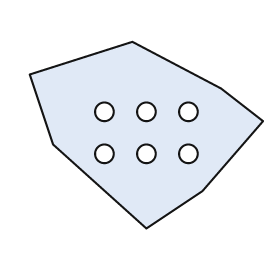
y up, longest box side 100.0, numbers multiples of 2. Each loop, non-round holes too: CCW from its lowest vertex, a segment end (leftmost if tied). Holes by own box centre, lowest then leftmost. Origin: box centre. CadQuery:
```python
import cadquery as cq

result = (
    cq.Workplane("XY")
    .moveTo(0.0, -40.0)
    .lineTo(24.0, -24.0)
    .lineTo(50.0, 6.0)
    .lineTo(32.0, 20.0)
    .lineTo(-6.0, 40.0)
    .lineTo(-50.0, 26.0)
    .lineTo(-40.0, -4.0)
    .close()
    .moveTo(-18.0, -8.0)
    .circle(4.0)
    .moveTo(0.0, -8.0)
    .circle(4.0)
    .moveTo(18.0, -8.0)
    .circle(4.0)
    .moveTo(-18.0, 10.0)
    .circle(4.0)
    .moveTo(0.0, 10.0)
    .circle(4.0)
    .moveTo(18.0, 10.0)
    .circle(4.0)
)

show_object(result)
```